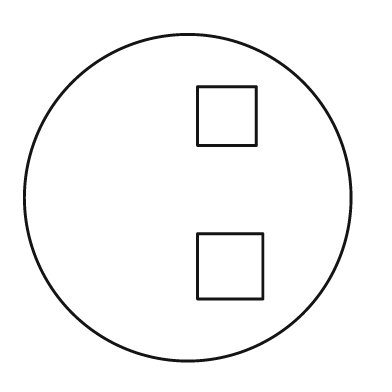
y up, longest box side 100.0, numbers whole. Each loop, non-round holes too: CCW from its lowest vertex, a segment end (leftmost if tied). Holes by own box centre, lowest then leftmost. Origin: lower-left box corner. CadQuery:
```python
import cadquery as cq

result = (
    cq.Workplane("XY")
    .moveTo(50.0, 50.0)
    .circle(50.0)
    .moveTo(53.0, 19.0)
    .lineTo(73.0, 19.0)
    .lineTo(73.0, 39.0)
    .lineTo(53.0, 39.0)
    .close()
    .moveTo(53.0, 66.0)
    .lineTo(71.0, 66.0)
    .lineTo(71.0, 84.0)
    .lineTo(53.0, 84.0)
    .close()
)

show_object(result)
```